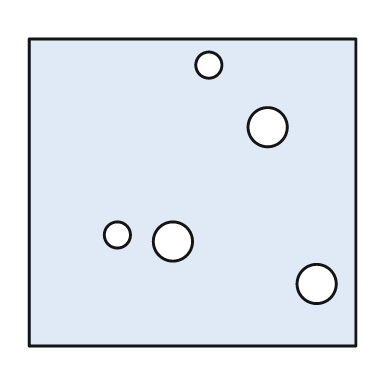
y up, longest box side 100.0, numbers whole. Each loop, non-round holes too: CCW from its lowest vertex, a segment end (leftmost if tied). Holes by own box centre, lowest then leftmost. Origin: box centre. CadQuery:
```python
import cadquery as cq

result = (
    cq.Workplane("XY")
    .moveTo(-50.0, -47.0)
    .lineTo(50.0, -47.0)
    .lineTo(50.0, 47.0)
    .lineTo(-50.0, 47.0)
    .close()
    .moveTo(38.0, -28.0)
    .circle(6.0)
    .moveTo(-6.0, -15.0)
    .circle(6.0)
    .moveTo(-23.0, -13.0)
    .circle(4.0)
    .moveTo(23.0, 20.0)
    .circle(6.0)
    .moveTo(5.0, 39.0)
    .circle(4.0)
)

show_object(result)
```